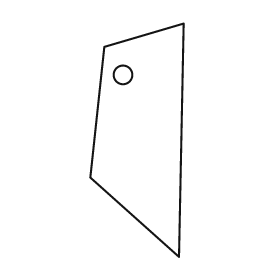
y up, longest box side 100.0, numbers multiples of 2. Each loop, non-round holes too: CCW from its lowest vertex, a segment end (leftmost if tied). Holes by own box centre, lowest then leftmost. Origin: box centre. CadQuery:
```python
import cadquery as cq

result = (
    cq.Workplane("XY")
    .moveTo(18.0, -50.0)
    .lineTo(20.0, 50.0)
    .lineTo(-14.0, 40.0)
    .lineTo(-20.0, -16.0)
    .close()
    .moveTo(-6.0, 28.0)
    .circle(4.0)
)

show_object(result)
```